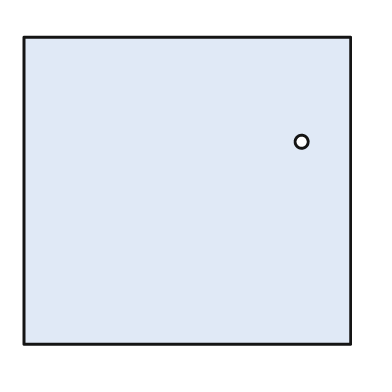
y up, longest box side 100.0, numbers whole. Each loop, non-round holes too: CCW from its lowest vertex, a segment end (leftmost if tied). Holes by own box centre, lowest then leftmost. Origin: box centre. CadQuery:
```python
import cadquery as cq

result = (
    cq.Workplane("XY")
    .moveTo(-50.0, -47.0)
    .lineTo(50.0, -47.0)
    .lineTo(50.0, 47.0)
    .lineTo(-50.0, 47.0)
    .close()
    .moveTo(35.0, 15.0)
    .circle(2.0)
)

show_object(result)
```